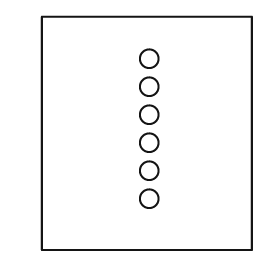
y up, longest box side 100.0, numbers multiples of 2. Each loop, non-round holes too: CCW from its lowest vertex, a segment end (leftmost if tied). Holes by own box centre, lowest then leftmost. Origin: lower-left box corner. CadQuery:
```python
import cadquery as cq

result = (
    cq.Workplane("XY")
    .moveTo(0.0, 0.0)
    .lineTo(90.0, 0.0)
    .lineTo(90.0, 100.0)
    .lineTo(0.0, 100.0)
    .close()
    .moveTo(46.0, 22.0)
    .circle(4.0)
    .moveTo(46.0, 34.0)
    .circle(4.0)
    .moveTo(46.0, 46.0)
    .circle(4.0)
    .moveTo(46.0, 58.0)
    .circle(4.0)
    .moveTo(46.0, 70.0)
    .circle(4.0)
    .moveTo(46.0, 82.0)
    .circle(4.0)
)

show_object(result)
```